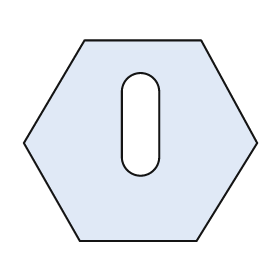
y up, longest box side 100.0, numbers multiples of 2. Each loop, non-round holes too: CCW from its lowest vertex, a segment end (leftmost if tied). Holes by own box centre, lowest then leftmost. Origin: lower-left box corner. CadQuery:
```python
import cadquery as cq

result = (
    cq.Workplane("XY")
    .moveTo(24.0, 0.0)
    .lineTo(74.0, 0.0)
    .lineTo(100.0, 42.0)
    .lineTo(76.0, 86.0)
    .lineTo(26.0, 86.0)
    .lineTo(0.0, 42.0)
    .close()
    .moveTo(42.0, 36.0)
    .threePointArc((50.0, 28.0), (58.0, 36.0))
    .lineTo(58.0, 64.0)
    .threePointArc((50.0, 72.0), (42.0, 64.0))
    .close()
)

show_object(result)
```